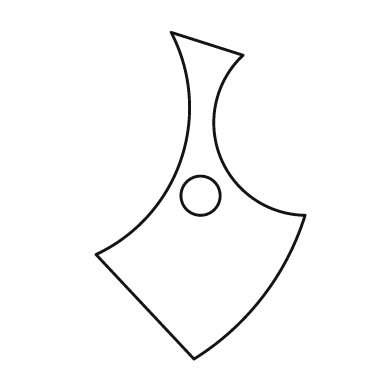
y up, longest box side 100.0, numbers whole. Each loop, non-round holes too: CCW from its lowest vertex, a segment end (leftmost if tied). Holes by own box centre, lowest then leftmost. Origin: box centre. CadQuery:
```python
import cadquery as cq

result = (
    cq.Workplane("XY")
    .moveTo(-2.0, -50.0)
    .threePointArc((19.0, -31.0), (32.0, -6.0))
    .threePointArc((6.0, 12.0), (13.0, 43.0))
    .lineTo(-9.0, 50.0)
    .threePointArc((-6.0, 11.0), (-32.0, -18.0))
    .close()
    .moveTo(0.0, 0.0)
    .circle(6.0)
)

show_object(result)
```